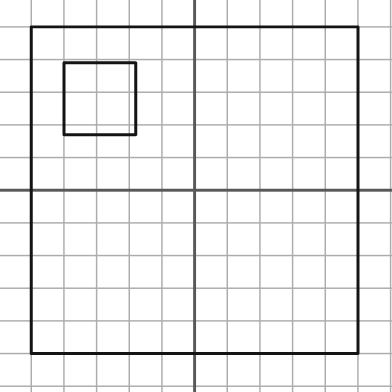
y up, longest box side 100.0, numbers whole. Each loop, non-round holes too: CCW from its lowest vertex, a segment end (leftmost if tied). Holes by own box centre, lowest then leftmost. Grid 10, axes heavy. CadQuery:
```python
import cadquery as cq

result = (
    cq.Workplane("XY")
    .moveTo(-50.0, -50.0)
    .lineTo(50.0, -50.0)
    .lineTo(50.0, 50.0)
    .lineTo(-50.0, 50.0)
    .close()
    .moveTo(-40.0, 17.0)
    .lineTo(-18.0, 17.0)
    .lineTo(-18.0, 39.0)
    .lineTo(-40.0, 39.0)
    .close()
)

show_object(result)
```